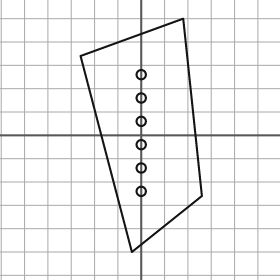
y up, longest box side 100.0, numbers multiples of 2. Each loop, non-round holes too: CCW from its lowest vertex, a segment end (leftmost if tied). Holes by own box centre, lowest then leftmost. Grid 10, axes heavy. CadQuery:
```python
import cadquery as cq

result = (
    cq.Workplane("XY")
    .moveTo(-4.0, -50.0)
    .lineTo(26.0, -26.0)
    .lineTo(18.0, 50.0)
    .lineTo(-26.0, 34.0)
    .close()
    .moveTo(0.0, -24.0)
    .circle(2.0)
    .moveTo(0.0, -14.0)
    .circle(2.0)
    .moveTo(0.0, -4.0)
    .circle(2.0)
    .moveTo(0.0, 6.0)
    .circle(2.0)
    .moveTo(0.0, 16.0)
    .circle(2.0)
    .moveTo(0.0, 26.0)
    .circle(2.0)
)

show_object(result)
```